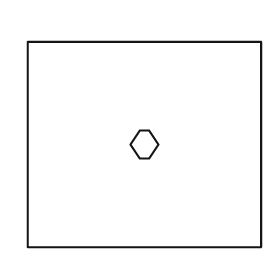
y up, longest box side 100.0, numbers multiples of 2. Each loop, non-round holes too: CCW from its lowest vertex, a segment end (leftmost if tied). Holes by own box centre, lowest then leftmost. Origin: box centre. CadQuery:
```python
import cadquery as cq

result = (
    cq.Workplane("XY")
    .moveTo(-50.0, -44.0)
    .lineTo(50.0, -44.0)
    .lineTo(50.0, 44.0)
    .lineTo(-50.0, 44.0)
    .close()
    .moveTo(-2.0, -6.0)
    .lineTo(2.0, -6.0)
    .lineTo(6.0, 0.0)
    .lineTo(2.0, 6.0)
    .lineTo(-2.0, 6.0)
    .lineTo(-6.0, 0.0)
    .close()
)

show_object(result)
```